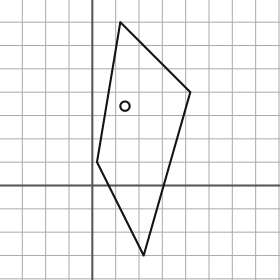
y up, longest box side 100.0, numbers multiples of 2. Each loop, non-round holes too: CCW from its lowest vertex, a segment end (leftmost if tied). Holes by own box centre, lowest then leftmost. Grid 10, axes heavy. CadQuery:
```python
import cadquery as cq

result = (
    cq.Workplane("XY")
    .moveTo(22.0, -30.0)
    .lineTo(42.0, 40.0)
    .lineTo(12.0, 70.0)
    .lineTo(2.0, 10.0)
    .close()
    .moveTo(14.0, 34.0)
    .circle(2.0)
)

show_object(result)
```